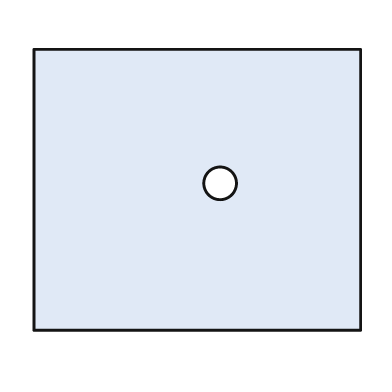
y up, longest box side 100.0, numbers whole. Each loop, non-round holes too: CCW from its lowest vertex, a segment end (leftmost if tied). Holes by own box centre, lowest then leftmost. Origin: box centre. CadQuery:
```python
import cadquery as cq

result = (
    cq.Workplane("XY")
    .moveTo(-50.0, -43.0)
    .lineTo(50.0, -43.0)
    .lineTo(50.0, 43.0)
    .lineTo(-50.0, 43.0)
    .close()
    .moveTo(7.0, 2.0)
    .circle(5.0)
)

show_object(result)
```